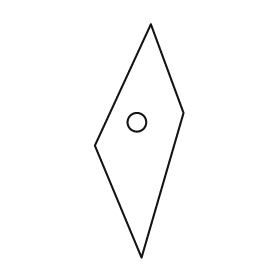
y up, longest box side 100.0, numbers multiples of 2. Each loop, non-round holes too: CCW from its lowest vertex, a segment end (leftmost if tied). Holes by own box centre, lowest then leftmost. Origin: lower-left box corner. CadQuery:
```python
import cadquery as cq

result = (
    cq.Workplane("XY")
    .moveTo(20.0, 0.0)
    .lineTo(38.0, 62.0)
    .lineTo(24.0, 100.0)
    .lineTo(0.0, 48.0)
    .close()
    .moveTo(18.0, 58.0)
    .circle(4.0)
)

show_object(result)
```